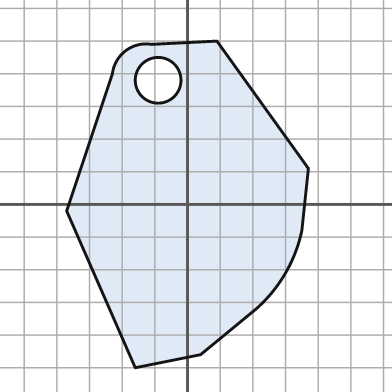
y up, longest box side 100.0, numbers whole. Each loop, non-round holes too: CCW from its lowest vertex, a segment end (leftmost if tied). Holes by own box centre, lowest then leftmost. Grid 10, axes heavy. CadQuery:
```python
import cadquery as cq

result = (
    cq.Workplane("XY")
    .moveTo(-16.0, -50.0)
    .lineTo(4.0, -46.0)
    .lineTo(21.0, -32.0)
    .threePointArc((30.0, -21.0), (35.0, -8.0))
    .lineTo(37.0, 11.0)
    .lineTo(9.0, 50.0)
    .lineTo(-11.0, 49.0)
    .threePointArc((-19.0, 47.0), (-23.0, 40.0))
    .lineTo(-37.0, -2.0)
    .close()
    .moveTo(-9.0, 38.0)
    .circle(7.0)
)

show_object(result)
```